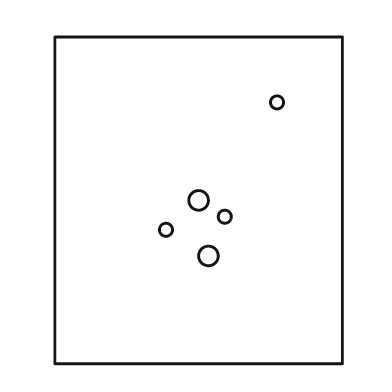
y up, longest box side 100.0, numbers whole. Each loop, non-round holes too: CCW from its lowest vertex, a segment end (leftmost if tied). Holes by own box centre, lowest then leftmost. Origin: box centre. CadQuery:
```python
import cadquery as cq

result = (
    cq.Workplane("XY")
    .moveTo(-44.0, -50.0)
    .lineTo(44.0, -50.0)
    .lineTo(44.0, 50.0)
    .lineTo(-44.0, 50.0)
    .close()
    .moveTo(3.0, -17.0)
    .circle(3.0)
    .moveTo(-10.0, -9.0)
    .circle(2.0)
    .moveTo(8.0, -5.0)
    .circle(2.0)
    .moveTo(0.0, 0.0)
    .circle(3.0)
    .moveTo(24.0, 30.0)
    .circle(2.0)
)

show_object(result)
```